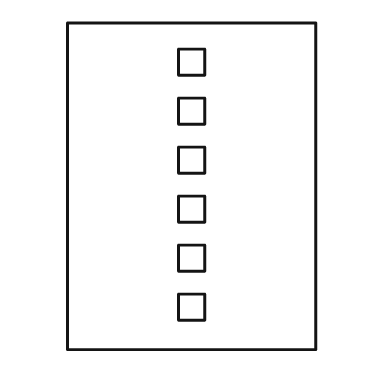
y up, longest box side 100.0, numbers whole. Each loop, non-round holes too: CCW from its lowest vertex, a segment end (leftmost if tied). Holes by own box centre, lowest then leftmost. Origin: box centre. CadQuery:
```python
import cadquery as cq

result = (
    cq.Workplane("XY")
    .moveTo(-38.0, -50.0)
    .lineTo(38.0, -50.0)
    .lineTo(38.0, 50.0)
    .lineTo(-38.0, 50.0)
    .close()
    .moveTo(-4.0, -41.0)
    .lineTo(4.0, -41.0)
    .lineTo(4.0, -33.0)
    .lineTo(-4.0, -33.0)
    .close()
    .moveTo(-4.0, -26.0)
    .lineTo(4.0, -26.0)
    .lineTo(4.0, -18.0)
    .lineTo(-4.0, -18.0)
    .close()
    .moveTo(-4.0, -11.0)
    .lineTo(4.0, -11.0)
    .lineTo(4.0, -3.0)
    .lineTo(-4.0, -3.0)
    .close()
    .moveTo(-4.0, 4.0)
    .lineTo(4.0, 4.0)
    .lineTo(4.0, 12.0)
    .lineTo(-4.0, 12.0)
    .close()
    .moveTo(-4.0, 19.0)
    .lineTo(4.0, 19.0)
    .lineTo(4.0, 27.0)
    .lineTo(-4.0, 27.0)
    .close()
    .moveTo(-4.0, 34.0)
    .lineTo(4.0, 34.0)
    .lineTo(4.0, 42.0)
    .lineTo(-4.0, 42.0)
    .close()
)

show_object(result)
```